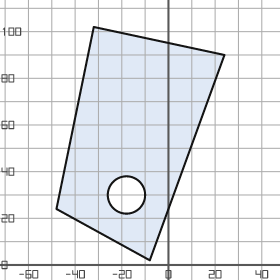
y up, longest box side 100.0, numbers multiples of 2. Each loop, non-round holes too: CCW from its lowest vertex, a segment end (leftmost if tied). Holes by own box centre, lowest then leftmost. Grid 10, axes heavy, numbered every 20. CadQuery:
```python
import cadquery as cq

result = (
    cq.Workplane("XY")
    .moveTo(-8.0, 2.0)
    .lineTo(24.0, 90.0)
    .lineTo(-32.0, 102.0)
    .lineTo(-48.0, 24.0)
    .close()
    .moveTo(-18.0, 30.0)
    .circle(8.0)
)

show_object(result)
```